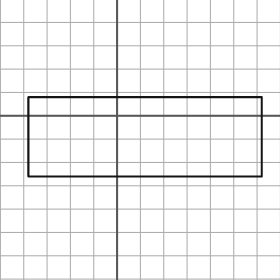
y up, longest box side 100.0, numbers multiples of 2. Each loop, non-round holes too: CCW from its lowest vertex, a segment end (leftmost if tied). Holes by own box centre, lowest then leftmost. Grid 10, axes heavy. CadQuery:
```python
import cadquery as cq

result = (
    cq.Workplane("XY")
    .moveTo(-38.0, -26.0)
    .lineTo(62.0, -26.0)
    .lineTo(62.0, 8.0)
    .lineTo(-38.0, 8.0)
    .close()
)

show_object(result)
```